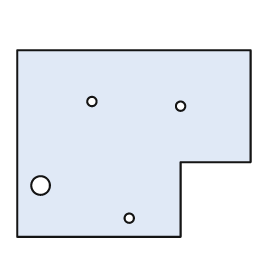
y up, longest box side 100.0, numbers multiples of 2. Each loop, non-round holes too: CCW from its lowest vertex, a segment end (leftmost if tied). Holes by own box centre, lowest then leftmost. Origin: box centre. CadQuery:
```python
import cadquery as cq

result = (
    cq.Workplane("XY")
    .moveTo(-50.0, -40.0)
    .lineTo(20.0, -40.0)
    .lineTo(20.0, -8.0)
    .lineTo(50.0, -8.0)
    .lineTo(50.0, 40.0)
    .lineTo(-50.0, 40.0)
    .close()
    .moveTo(-2.0, -32.0)
    .circle(2.0)
    .moveTo(-40.0, -18.0)
    .circle(4.0)
    .moveTo(20.0, 16.0)
    .circle(2.0)
    .moveTo(-18.0, 18.0)
    .circle(2.0)
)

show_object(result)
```